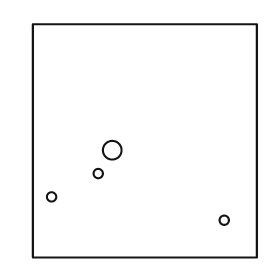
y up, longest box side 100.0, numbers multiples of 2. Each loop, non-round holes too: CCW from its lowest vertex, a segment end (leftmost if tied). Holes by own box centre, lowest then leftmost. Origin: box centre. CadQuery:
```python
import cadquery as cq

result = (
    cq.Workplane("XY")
    .moveTo(-48.0, -50.0)
    .lineTo(48.0, -50.0)
    .lineTo(48.0, 50.0)
    .lineTo(-48.0, 50.0)
    .close()
    .moveTo(34.0, -34.0)
    .circle(2.0)
    .moveTo(-40.0, -24.0)
    .circle(2.0)
    .moveTo(-20.0, -14.0)
    .circle(2.0)
    .moveTo(-14.0, -4.0)
    .circle(4.0)
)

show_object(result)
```